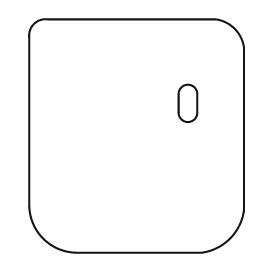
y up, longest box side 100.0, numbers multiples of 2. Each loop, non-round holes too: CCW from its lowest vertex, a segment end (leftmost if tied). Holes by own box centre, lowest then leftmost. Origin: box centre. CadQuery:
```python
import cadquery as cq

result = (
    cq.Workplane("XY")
    .moveTo(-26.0, -50.0)
    .lineTo(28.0, -50.0)
    .threePointArc((40.0, -44.0), (46.0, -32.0))
    .lineTo(46.0, 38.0)
    .threePointArc((42.0, 46.0), (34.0, 50.0))
    .lineTo(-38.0, 50.0)
    .threePointArc((-44.0, 48.0), (-46.0, 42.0))
    .lineTo(-46.0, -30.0)
    .threePointArc((-40.0, -44.0), (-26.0, -50.0))
    .close()
    .moveTo(18.0, 10.0)
    .threePointArc((22.0, 6.0), (26.0, 10.0))
    .lineTo(26.0, 18.0)
    .threePointArc((22.0, 22.0), (18.0, 18.0))
    .close()
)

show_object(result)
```